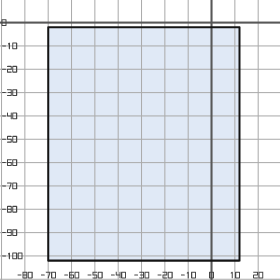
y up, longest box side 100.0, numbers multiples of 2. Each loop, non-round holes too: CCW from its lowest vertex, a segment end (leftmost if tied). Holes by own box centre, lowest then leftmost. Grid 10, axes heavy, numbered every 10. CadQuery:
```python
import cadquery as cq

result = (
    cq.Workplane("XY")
    .moveTo(-70.0, -102.0)
    .lineTo(12.0, -102.0)
    .lineTo(12.0, -2.0)
    .lineTo(-70.0, -2.0)
    .close()
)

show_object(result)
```